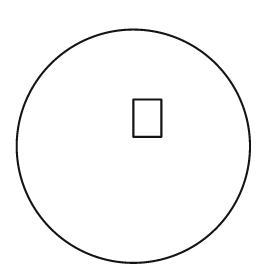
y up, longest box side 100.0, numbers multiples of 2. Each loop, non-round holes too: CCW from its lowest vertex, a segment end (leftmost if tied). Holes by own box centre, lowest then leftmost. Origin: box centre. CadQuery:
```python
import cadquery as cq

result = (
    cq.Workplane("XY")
    .moveTo(0.0, 0.0)
    .circle(50.0)
    .moveTo(0.0, 4.0)
    .lineTo(12.0, 4.0)
    .lineTo(12.0, 20.0)
    .lineTo(0.0, 20.0)
    .close()
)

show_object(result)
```